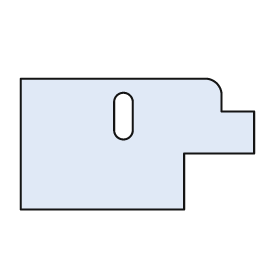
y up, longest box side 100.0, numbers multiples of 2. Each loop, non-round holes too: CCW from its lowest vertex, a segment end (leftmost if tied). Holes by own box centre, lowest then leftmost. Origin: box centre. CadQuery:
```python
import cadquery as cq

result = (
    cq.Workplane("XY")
    .moveTo(-50.0, -28.0)
    .lineTo(20.0, -28.0)
    .lineTo(20.0, -4.0)
    .lineTo(50.0, -4.0)
    .lineTo(50.0, 14.0)
    .lineTo(36.0, 14.0)
    .lineTo(36.0, 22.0)
    .threePointArc((34.0, 26.0), (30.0, 28.0))
    .lineTo(-50.0, 28.0)
    .close()
    .moveTo(-10.0, 6.0)
    .threePointArc((-6.0, 2.0), (-2.0, 6.0))
    .lineTo(-2.0, 18.0)
    .threePointArc((-6.0, 22.0), (-10.0, 18.0))
    .close()
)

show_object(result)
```